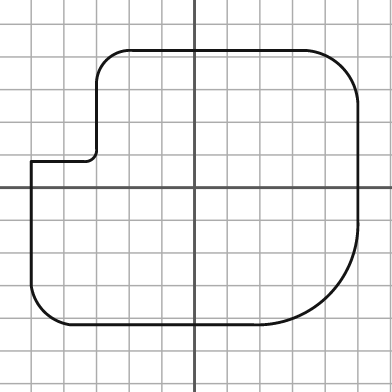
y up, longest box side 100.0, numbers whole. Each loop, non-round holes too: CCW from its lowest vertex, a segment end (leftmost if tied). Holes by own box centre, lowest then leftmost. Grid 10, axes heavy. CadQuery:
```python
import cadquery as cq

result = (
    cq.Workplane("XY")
    .moveTo(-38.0, -42.0)
    .lineTo(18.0, -42.0)
    .threePointArc((41.0, -33.0), (50.0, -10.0))
    .lineTo(50.0, 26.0)
    .threePointArc((45.0, 37.0), (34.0, 42.0))
    .lineTo(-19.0, 42.0)
    .threePointArc((-27.0, 39.0), (-30.0, 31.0))
    .lineTo(-30.0, 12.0)
    .threePointArc((-31.0, 9.0), (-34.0, 8.0))
    .lineTo(-50.0, 8.0)
    .lineTo(-50.0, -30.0)
    .threePointArc((-46.0, -38.0), (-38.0, -42.0))
    .close()
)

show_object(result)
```